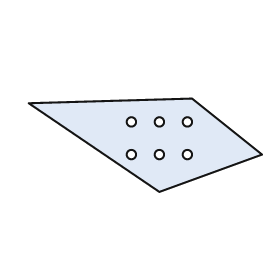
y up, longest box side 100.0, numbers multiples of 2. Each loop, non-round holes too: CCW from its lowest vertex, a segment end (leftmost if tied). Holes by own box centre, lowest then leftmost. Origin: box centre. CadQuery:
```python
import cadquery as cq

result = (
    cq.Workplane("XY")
    .moveTo(6.0, -20.0)
    .lineTo(50.0, -4.0)
    .lineTo(20.0, 20.0)
    .lineTo(-50.0, 18.0)
    .close()
    .moveTo(-6.0, -4.0)
    .circle(2.0)
    .moveTo(6.0, -4.0)
    .circle(2.0)
    .moveTo(18.0, -4.0)
    .circle(2.0)
    .moveTo(-6.0, 10.0)
    .circle(2.0)
    .moveTo(6.0, 10.0)
    .circle(2.0)
    .moveTo(18.0, 10.0)
    .circle(2.0)
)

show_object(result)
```